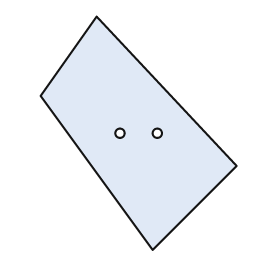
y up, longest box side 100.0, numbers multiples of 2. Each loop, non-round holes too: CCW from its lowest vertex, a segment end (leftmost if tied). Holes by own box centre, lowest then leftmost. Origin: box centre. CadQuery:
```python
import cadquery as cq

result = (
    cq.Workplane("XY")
    .moveTo(6.0, -50.0)
    .lineTo(42.0, -14.0)
    .lineTo(-18.0, 50.0)
    .lineTo(-42.0, 16.0)
    .close()
    .moveTo(-8.0, 0.0)
    .circle(2.0)
    .moveTo(8.0, 0.0)
    .circle(2.0)
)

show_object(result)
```